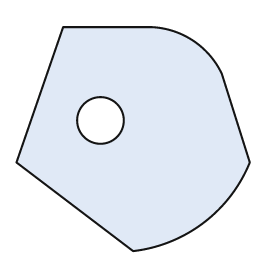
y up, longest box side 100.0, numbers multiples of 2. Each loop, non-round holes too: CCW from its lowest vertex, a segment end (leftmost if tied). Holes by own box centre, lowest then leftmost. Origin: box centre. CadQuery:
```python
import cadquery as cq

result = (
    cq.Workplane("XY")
    .moveTo(0.0, -48.0)
    .threePointArc((30.0, -36.0), (50.0, -10.0))
    .lineTo(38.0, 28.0)
    .threePointArc((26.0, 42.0), (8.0, 48.0))
    .lineTo(-30.0, 48.0)
    .lineTo(-50.0, -10.0)
    .close()
    .moveTo(-14.0, 8.0)
    .circle(10.0)
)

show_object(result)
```